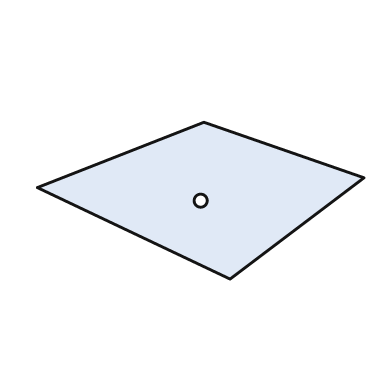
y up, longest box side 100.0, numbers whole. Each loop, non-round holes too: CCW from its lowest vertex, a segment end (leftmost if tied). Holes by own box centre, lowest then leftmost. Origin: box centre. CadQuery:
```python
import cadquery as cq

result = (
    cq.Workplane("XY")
    .moveTo(9.0, -24.0)
    .lineTo(50.0, 7.0)
    .lineTo(1.0, 24.0)
    .lineTo(-50.0, 4.0)
    .close()
    .moveTo(0.0, 0.0)
    .circle(2.0)
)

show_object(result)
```